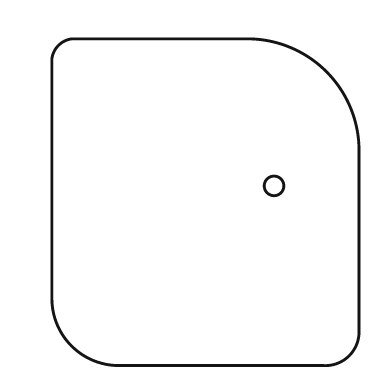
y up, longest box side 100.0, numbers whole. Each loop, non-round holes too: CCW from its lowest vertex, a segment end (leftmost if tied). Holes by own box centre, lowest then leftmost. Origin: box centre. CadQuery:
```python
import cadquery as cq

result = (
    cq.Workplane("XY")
    .moveTo(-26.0, -50.0)
    .lineTo(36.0, -50.0)
    .threePointArc((44.0, -47.0), (47.0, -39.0))
    .lineTo(47.0, 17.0)
    .threePointArc((37.0, 40.0), (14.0, 50.0))
    .lineTo(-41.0, 50.0)
    .threePointArc((-45.0, 48.0), (-47.0, 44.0))
    .lineTo(-47.0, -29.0)
    .threePointArc((-41.0, -44.0), (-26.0, -50.0))
    .close()
    .moveTo(21.0, 5.0)
    .circle(3.0)
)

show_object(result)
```